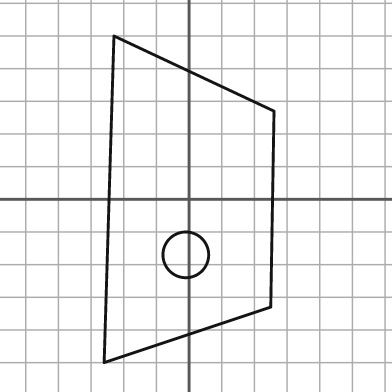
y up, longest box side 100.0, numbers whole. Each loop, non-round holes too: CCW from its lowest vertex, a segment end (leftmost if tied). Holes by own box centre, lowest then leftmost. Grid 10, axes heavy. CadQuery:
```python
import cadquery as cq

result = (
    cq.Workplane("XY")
    .moveTo(-26.0, -50.0)
    .lineTo(25.0, -33.0)
    .lineTo(26.0, 27.0)
    .lineTo(-23.0, 50.0)
    .close()
    .moveTo(-1.0, -17.0)
    .circle(7.0)
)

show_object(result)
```